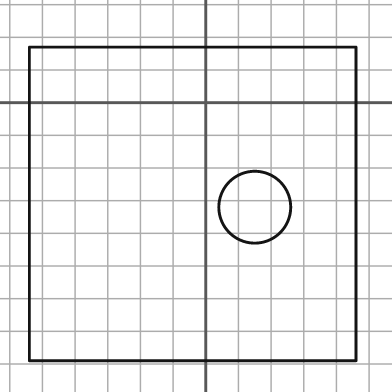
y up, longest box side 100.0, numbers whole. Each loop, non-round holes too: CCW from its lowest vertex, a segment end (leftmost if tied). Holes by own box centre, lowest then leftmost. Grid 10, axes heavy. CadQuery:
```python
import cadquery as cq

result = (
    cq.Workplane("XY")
    .moveTo(-54.0, -79.0)
    .lineTo(46.0, -79.0)
    .lineTo(46.0, 17.0)
    .lineTo(-54.0, 17.0)
    .close()
    .moveTo(15.0, -32.0)
    .circle(11.0)
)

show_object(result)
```